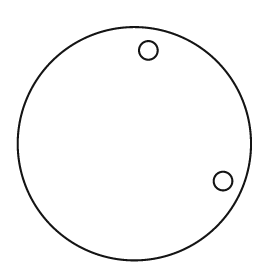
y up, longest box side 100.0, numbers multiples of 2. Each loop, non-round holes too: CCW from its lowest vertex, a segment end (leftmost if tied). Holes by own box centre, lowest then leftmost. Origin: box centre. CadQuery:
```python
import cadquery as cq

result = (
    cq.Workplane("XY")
    .moveTo(0.0, 0.0)
    .circle(50.0)
    .moveTo(38.0, -16.0)
    .circle(4.0)
    .moveTo(6.0, 40.0)
    .circle(4.0)
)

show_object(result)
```